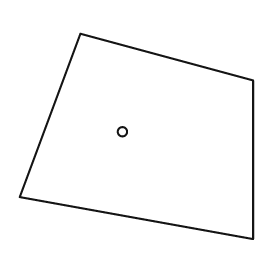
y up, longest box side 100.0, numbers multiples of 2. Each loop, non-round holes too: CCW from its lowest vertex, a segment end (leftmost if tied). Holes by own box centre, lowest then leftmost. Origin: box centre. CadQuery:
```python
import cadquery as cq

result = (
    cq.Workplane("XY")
    .moveTo(50.0, -44.0)
    .lineTo(50.0, 24.0)
    .lineTo(-24.0, 44.0)
    .lineTo(-50.0, -26.0)
    .close()
    .moveTo(-6.0, 2.0)
    .circle(2.0)
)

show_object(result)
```